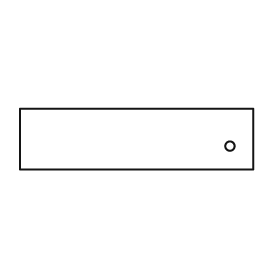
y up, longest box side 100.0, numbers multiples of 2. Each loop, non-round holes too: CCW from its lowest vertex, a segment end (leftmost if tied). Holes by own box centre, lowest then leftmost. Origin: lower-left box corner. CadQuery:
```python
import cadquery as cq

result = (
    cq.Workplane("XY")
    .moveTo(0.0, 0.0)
    .lineTo(100.0, 0.0)
    .lineTo(100.0, 26.0)
    .lineTo(0.0, 26.0)
    .close()
    .moveTo(90.0, 10.0)
    .circle(2.0)
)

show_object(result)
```